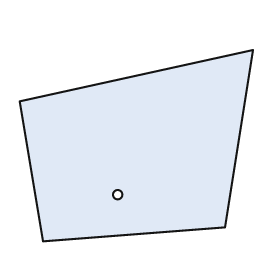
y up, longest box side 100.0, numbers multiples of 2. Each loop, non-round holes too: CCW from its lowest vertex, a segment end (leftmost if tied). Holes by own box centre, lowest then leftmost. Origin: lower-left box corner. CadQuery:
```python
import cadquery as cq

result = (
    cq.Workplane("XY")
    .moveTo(10.0, 0.0)
    .lineTo(88.0, 6.0)
    .lineTo(100.0, 82.0)
    .lineTo(0.0, 60.0)
    .close()
    .moveTo(42.0, 20.0)
    .circle(2.0)
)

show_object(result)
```